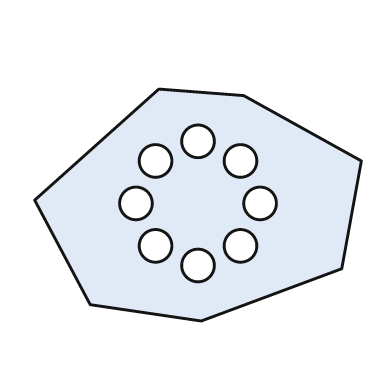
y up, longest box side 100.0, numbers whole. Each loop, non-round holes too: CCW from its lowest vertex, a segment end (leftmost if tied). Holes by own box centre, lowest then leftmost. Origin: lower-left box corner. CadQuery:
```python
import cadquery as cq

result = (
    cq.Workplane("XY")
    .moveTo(51.0, 0.0)
    .lineTo(94.0, 16.0)
    .lineTo(100.0, 49.0)
    .lineTo(64.0, 69.0)
    .lineTo(38.0, 71.0)
    .lineTo(0.0, 37.0)
    .lineTo(17.0, 5.0)
    .close()
    .moveTo(50.0, 17.0)
    .circle(5.0)
    .moveTo(37.0, 23.0)
    .circle(5.0)
    .moveTo(63.0, 23.0)
    .circle(5.0)
    .moveTo(31.0, 36.0)
    .circle(5.0)
    .moveTo(69.0, 36.0)
    .circle(5.0)
    .moveTo(37.0, 49.0)
    .circle(5.0)
    .moveTo(63.0, 49.0)
    .circle(5.0)
    .moveTo(50.0, 55.0)
    .circle(5.0)
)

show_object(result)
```